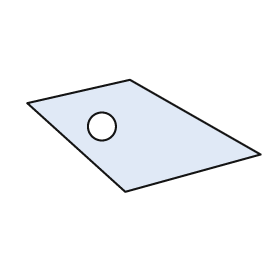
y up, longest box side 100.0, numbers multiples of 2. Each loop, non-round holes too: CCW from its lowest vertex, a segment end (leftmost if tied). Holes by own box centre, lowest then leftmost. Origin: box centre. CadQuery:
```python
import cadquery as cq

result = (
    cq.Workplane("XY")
    .moveTo(-8.0, -24.0)
    .lineTo(50.0, -8.0)
    .lineTo(-6.0, 24.0)
    .lineTo(-50.0, 14.0)
    .close()
    .moveTo(-18.0, 4.0)
    .circle(6.0)
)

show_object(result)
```